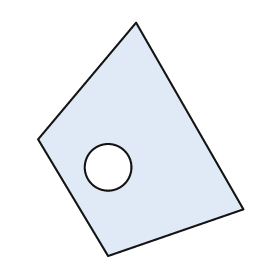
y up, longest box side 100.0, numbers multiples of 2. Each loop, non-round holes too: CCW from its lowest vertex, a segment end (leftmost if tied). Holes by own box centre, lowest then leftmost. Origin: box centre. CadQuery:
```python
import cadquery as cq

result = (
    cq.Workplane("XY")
    .moveTo(-14.0, -50.0)
    .lineTo(44.0, -30.0)
    .lineTo(-2.0, 50.0)
    .lineTo(-44.0, 0.0)
    .close()
    .moveTo(-14.0, -12.0)
    .circle(10.0)
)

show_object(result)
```